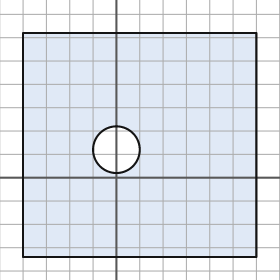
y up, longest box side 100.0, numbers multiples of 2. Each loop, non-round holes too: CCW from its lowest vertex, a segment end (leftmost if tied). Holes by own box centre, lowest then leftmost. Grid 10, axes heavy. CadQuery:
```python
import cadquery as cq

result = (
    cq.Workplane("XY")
    .moveTo(-40.0, -34.0)
    .lineTo(60.0, -34.0)
    .lineTo(60.0, 62.0)
    .lineTo(-40.0, 62.0)
    .close()
    .moveTo(0.0, 12.0)
    .circle(10.0)
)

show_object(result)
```